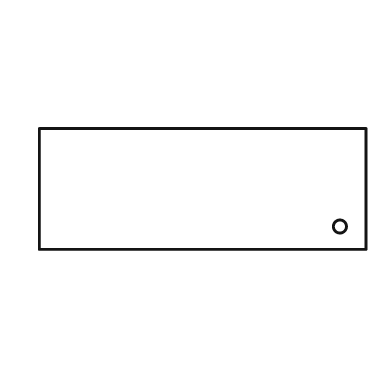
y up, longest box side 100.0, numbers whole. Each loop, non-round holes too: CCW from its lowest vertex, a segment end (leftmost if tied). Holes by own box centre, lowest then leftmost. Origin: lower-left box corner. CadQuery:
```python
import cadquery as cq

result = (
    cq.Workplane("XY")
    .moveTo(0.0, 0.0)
    .lineTo(100.0, 0.0)
    .lineTo(100.0, 37.0)
    .lineTo(0.0, 37.0)
    .close()
    .moveTo(92.0, 7.0)
    .circle(2.0)
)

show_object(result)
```